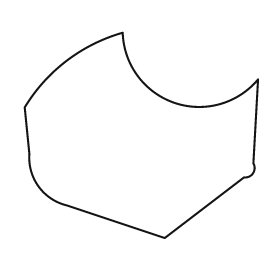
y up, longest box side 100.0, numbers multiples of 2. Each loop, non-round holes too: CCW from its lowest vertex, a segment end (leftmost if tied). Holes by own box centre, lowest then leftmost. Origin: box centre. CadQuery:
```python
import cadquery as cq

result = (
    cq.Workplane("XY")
    .moveTo(10.0, -44.0)
    .lineTo(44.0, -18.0)
    .threePointArc((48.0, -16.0), (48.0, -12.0))
    .lineTo(50.0, 24.0)
    .threePointArc((14.0, 14.0), (-8.0, 44.0))
    .threePointArc((-32.0, 32.0), (-50.0, 12.0))
    .lineTo(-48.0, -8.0)
    .threePointArc((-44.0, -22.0), (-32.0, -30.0))
    .close()
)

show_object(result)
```